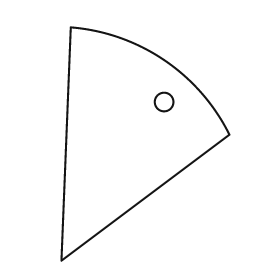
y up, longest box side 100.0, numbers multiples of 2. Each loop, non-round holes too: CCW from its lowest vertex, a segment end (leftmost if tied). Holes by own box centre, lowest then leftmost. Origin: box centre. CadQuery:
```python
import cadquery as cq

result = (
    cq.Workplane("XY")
    .moveTo(-36.0, -50.0)
    .lineTo(36.0, 4.0)
    .threePointArc((8.0, 36.0), (-32.0, 50.0))
    .close()
    .moveTo(8.0, 18.0)
    .circle(4.0)
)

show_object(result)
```